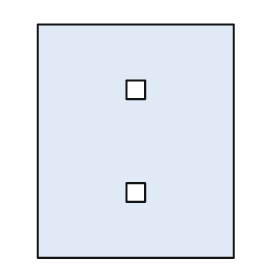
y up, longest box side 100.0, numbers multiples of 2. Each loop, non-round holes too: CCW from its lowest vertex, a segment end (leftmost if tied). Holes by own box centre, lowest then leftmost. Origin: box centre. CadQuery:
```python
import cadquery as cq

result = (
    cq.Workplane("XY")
    .moveTo(-42.0, -50.0)
    .lineTo(42.0, -50.0)
    .lineTo(42.0, 50.0)
    .lineTo(-42.0, 50.0)
    .close()
    .moveTo(-4.0, -26.0)
    .lineTo(4.0, -26.0)
    .lineTo(4.0, -18.0)
    .lineTo(-4.0, -18.0)
    .close()
    .moveTo(-4.0, 18.0)
    .lineTo(4.0, 18.0)
    .lineTo(4.0, 26.0)
    .lineTo(-4.0, 26.0)
    .close()
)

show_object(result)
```